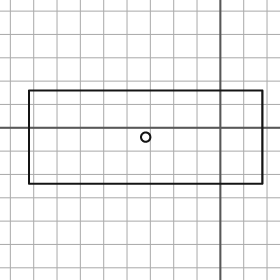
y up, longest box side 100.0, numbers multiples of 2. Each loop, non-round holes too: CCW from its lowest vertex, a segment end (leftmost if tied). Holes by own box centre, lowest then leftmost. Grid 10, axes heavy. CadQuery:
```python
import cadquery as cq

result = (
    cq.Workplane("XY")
    .moveTo(-82.0, -24.0)
    .lineTo(18.0, -24.0)
    .lineTo(18.0, 16.0)
    .lineTo(-82.0, 16.0)
    .close()
    .moveTo(-32.0, -4.0)
    .circle(2.0)
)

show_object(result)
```